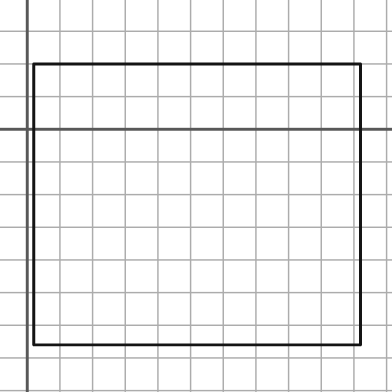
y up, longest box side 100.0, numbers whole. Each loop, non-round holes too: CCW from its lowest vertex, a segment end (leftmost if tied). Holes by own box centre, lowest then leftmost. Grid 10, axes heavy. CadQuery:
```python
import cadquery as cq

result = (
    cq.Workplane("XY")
    .moveTo(2.0, -66.0)
    .lineTo(102.0, -66.0)
    .lineTo(102.0, 20.0)
    .lineTo(2.0, 20.0)
    .close()
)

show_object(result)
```